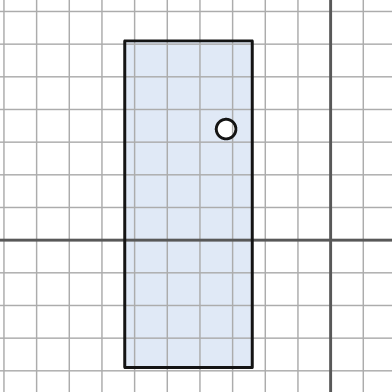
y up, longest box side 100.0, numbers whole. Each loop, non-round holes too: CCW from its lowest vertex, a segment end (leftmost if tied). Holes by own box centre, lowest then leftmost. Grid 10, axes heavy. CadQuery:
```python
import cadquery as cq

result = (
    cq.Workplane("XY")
    .moveTo(-63.0, -39.0)
    .lineTo(-24.0, -39.0)
    .lineTo(-24.0, 61.0)
    .lineTo(-63.0, 61.0)
    .close()
    .moveTo(-32.0, 34.0)
    .circle(3.0)
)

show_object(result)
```